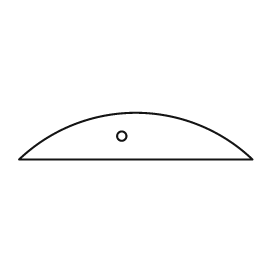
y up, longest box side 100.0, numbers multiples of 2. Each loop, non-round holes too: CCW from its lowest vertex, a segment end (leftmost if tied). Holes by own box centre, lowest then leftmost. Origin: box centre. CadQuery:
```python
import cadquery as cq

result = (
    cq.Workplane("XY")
    .moveTo(-50.0, -10.0)
    .lineTo(50.0, -10.0)
    .threePointArc((0.0, 10.0), (-50.0, -10.0))
    .close()
    .moveTo(-6.0, 0.0)
    .circle(2.0)
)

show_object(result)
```